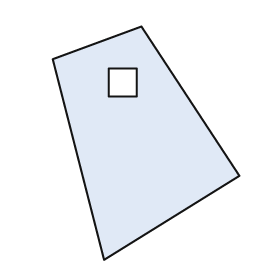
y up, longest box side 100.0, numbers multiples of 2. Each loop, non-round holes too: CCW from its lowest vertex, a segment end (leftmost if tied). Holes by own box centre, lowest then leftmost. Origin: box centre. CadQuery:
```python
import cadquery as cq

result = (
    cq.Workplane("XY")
    .moveTo(-18.0, -50.0)
    .lineTo(40.0, -14.0)
    .lineTo(-2.0, 50.0)
    .lineTo(-40.0, 36.0)
    .close()
    .moveTo(-16.0, 20.0)
    .lineTo(-4.0, 20.0)
    .lineTo(-4.0, 32.0)
    .lineTo(-16.0, 32.0)
    .close()
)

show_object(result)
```